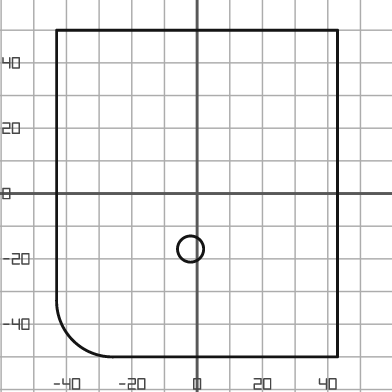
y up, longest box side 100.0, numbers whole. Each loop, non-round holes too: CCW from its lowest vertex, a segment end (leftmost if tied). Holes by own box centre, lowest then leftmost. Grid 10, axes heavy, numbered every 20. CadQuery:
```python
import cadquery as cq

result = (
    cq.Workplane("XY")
    .moveTo(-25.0, -50.0)
    .lineTo(43.0, -50.0)
    .lineTo(43.0, 50.0)
    .lineTo(-43.0, 50.0)
    .lineTo(-43.0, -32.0)
    .threePointArc((-38.0, -45.0), (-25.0, -50.0))
    .close()
    .moveTo(-2.0, -17.0)
    .circle(4.0)
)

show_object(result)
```